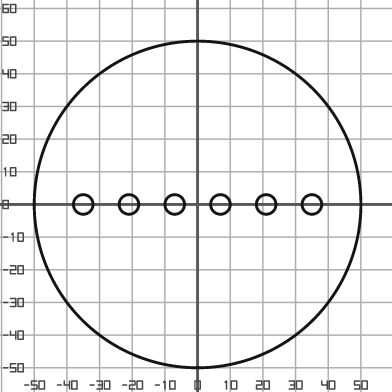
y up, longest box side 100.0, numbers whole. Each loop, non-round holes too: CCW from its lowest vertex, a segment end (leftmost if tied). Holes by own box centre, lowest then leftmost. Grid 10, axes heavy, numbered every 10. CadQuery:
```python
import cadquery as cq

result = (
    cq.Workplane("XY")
    .moveTo(0.0, 0.0)
    .circle(50.0)
    .moveTo(-35.0, 0.0)
    .circle(3.0)
    .moveTo(-21.0, 0.0)
    .circle(3.0)
    .moveTo(-7.0, 0.0)
    .circle(3.0)
    .moveTo(7.0, 0.0)
    .circle(3.0)
    .moveTo(21.0, 0.0)
    .circle(3.0)
    .moveTo(35.0, 0.0)
    .circle(3.0)
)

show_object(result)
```